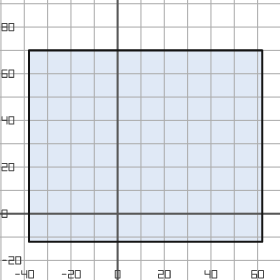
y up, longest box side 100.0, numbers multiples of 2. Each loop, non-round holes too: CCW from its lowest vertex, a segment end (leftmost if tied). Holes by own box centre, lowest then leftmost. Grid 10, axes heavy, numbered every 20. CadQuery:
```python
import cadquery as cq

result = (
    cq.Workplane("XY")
    .moveTo(-38.0, -12.0)
    .lineTo(62.0, -12.0)
    .lineTo(62.0, 70.0)
    .lineTo(-38.0, 70.0)
    .close()
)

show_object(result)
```